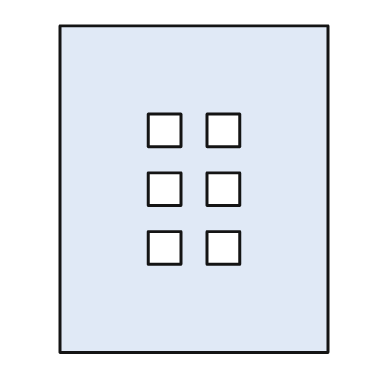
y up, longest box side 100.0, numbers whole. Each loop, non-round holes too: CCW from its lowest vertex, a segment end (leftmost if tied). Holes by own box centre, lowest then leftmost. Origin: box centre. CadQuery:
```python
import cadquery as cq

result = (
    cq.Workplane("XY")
    .moveTo(-41.0, -50.0)
    .lineTo(41.0, -50.0)
    .lineTo(41.0, 50.0)
    .lineTo(-41.0, 50.0)
    .close()
    .moveTo(-14.0, -23.0)
    .lineTo(-4.0, -23.0)
    .lineTo(-4.0, -13.0)
    .lineTo(-14.0, -13.0)
    .close()
    .moveTo(4.0, -23.0)
    .lineTo(14.0, -23.0)
    .lineTo(14.0, -13.0)
    .lineTo(4.0, -13.0)
    .close()
    .moveTo(-14.0, -5.0)
    .lineTo(-4.0, -5.0)
    .lineTo(-4.0, 5.0)
    .lineTo(-14.0, 5.0)
    .close()
    .moveTo(4.0, -5.0)
    .lineTo(14.0, -5.0)
    .lineTo(14.0, 5.0)
    .lineTo(4.0, 5.0)
    .close()
    .moveTo(-14.0, 13.0)
    .lineTo(-4.0, 13.0)
    .lineTo(-4.0, 23.0)
    .lineTo(-14.0, 23.0)
    .close()
    .moveTo(4.0, 13.0)
    .lineTo(14.0, 13.0)
    .lineTo(14.0, 23.0)
    .lineTo(4.0, 23.0)
    .close()
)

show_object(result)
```